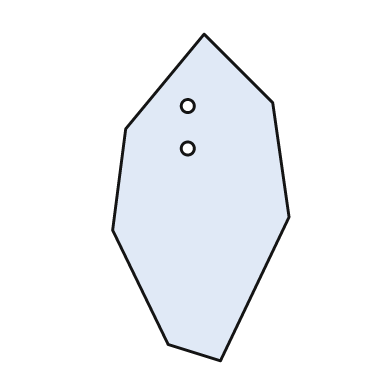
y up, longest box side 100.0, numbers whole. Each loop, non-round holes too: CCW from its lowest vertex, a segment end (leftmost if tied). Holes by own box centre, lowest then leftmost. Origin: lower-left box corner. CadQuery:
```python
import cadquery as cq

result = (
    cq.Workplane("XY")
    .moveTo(33.0, 0.0)
    .lineTo(54.0, 44.0)
    .lineTo(49.0, 79.0)
    .lineTo(28.0, 100.0)
    .lineTo(4.0, 71.0)
    .lineTo(0.0, 40.0)
    .lineTo(17.0, 5.0)
    .close()
    .moveTo(23.0, 65.0)
    .circle(2.0)
    .moveTo(23.0, 78.0)
    .circle(2.0)
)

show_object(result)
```